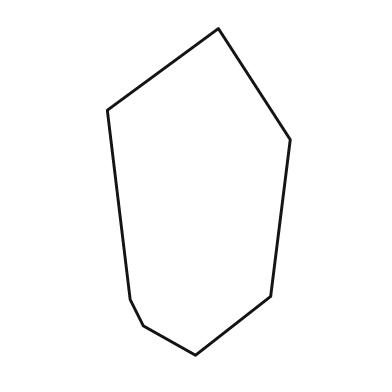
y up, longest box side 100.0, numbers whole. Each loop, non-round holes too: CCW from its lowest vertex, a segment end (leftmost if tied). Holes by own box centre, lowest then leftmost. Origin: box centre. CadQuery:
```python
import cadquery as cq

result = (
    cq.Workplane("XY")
    .moveTo(-1.0, -50.0)
    .lineTo(22.0, -32.0)
    .lineTo(28.0, 16.0)
    .lineTo(6.0, 50.0)
    .lineTo(-28.0, 25.0)
    .lineTo(-21.0, -33.0)
    .lineTo(-17.0, -41.0)
    .close()
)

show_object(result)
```